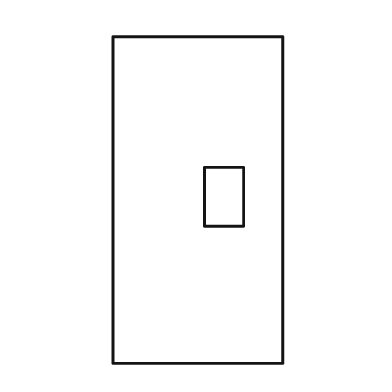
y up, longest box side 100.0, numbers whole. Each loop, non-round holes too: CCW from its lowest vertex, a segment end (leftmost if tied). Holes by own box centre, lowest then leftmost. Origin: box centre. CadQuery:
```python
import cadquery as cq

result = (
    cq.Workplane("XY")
    .moveTo(-26.0, -50.0)
    .lineTo(26.0, -50.0)
    .lineTo(26.0, 50.0)
    .lineTo(-26.0, 50.0)
    .close()
    .moveTo(2.0, -8.0)
    .lineTo(14.0, -8.0)
    .lineTo(14.0, 10.0)
    .lineTo(2.0, 10.0)
    .close()
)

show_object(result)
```